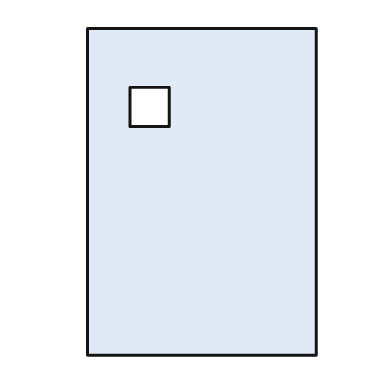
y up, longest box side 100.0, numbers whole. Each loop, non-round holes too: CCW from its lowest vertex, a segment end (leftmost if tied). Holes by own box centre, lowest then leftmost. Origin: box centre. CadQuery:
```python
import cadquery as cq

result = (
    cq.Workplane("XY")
    .moveTo(-35.0, -50.0)
    .lineTo(35.0, -50.0)
    .lineTo(35.0, 50.0)
    .lineTo(-35.0, 50.0)
    .close()
    .moveTo(-22.0, 20.0)
    .lineTo(-10.0, 20.0)
    .lineTo(-10.0, 32.0)
    .lineTo(-22.0, 32.0)
    .close()
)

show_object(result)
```